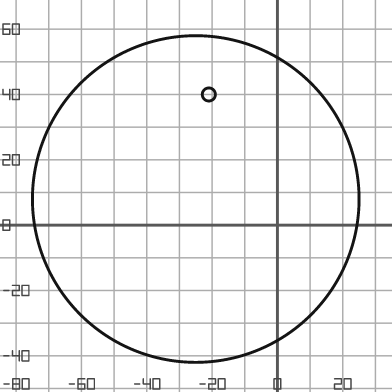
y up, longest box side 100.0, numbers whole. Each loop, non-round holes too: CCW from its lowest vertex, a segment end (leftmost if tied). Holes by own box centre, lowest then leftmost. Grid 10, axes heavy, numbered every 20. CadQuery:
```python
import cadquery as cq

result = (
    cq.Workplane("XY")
    .moveTo(-25.0, 8.0)
    .circle(50.0)
    .moveTo(-21.0, 40.0)
    .circle(2.0)
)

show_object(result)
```